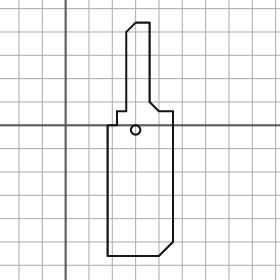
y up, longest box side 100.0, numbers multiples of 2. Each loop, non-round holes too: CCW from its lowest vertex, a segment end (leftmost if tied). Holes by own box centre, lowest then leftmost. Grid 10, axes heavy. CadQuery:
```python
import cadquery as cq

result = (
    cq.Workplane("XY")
    .moveTo(18.0, -56.0)
    .lineTo(40.0, -56.0)
    .lineTo(46.0, -50.0)
    .lineTo(46.0, 6.0)
    .lineTo(40.0, 6.0)
    .lineTo(36.0, 10.0)
    .lineTo(36.0, 44.0)
    .lineTo(30.0, 44.0)
    .lineTo(26.0, 40.0)
    .lineTo(26.0, 6.0)
    .lineTo(22.0, 6.0)
    .lineTo(22.0, 0.0)
    .lineTo(18.0, 0.0)
    .close()
    .moveTo(30.0, -2.0)
    .circle(2.0)
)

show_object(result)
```